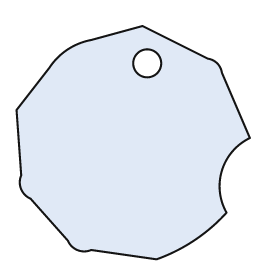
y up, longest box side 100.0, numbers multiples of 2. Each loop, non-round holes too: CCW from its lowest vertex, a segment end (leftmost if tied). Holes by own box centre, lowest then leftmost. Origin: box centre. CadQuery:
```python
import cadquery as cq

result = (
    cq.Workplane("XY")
    .moveTo(10.0, -50.0)
    .threePointArc((26.0, -42.0), (40.0, -30.0))
    .threePointArc((38.0, -12.0), (50.0, 2.0))
    .lineTo(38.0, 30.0)
    .threePointArc((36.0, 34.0), (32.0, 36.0))
    .lineTo(4.0, 50.0)
    .lineTo(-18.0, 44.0)
    .threePointArc((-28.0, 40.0), (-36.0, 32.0))
    .lineTo(-50.0, 14.0)
    .lineTo(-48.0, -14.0)
    .threePointArc((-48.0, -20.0), (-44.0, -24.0))
    .lineTo(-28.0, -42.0)
    .threePointArc((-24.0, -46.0), (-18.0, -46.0))
    .close()
    .moveTo(6.0, 34.0)
    .circle(6.0)
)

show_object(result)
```